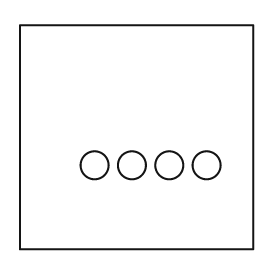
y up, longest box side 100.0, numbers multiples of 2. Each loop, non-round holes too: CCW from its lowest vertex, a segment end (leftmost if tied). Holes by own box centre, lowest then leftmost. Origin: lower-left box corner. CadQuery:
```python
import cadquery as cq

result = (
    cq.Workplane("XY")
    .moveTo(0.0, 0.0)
    .lineTo(100.0, 0.0)
    .lineTo(100.0, 96.0)
    .lineTo(0.0, 96.0)
    .close()
    .moveTo(32.0, 36.0)
    .circle(6.0)
    .moveTo(48.0, 36.0)
    .circle(6.0)
    .moveTo(64.0, 36.0)
    .circle(6.0)
    .moveTo(80.0, 36.0)
    .circle(6.0)
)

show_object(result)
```